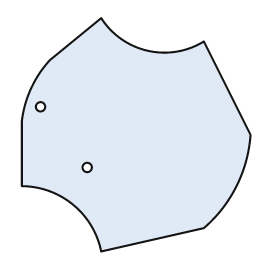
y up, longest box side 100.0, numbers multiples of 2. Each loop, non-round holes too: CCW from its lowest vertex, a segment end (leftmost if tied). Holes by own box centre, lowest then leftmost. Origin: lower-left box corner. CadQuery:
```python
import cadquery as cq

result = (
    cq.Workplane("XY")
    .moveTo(34.0, 0.0)
    .lineTo(78.0, 10.0)
    .threePointArc((92.0, 28.0), (98.0, 50.0))
    .lineTo(78.0, 90.0)
    .threePointArc((54.0, 86.0), (34.0, 100.0))
    .lineTo(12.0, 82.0)
    .threePointArc((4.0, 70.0), (0.0, 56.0))
    .lineTo(0.0, 28.0)
    .threePointArc((22.0, 20.0), (34.0, 0.0))
    .close()
    .moveTo(28.0, 36.0)
    .circle(2.0)
    .moveTo(8.0, 62.0)
    .circle(2.0)
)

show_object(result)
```